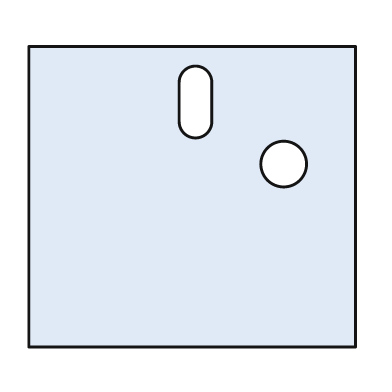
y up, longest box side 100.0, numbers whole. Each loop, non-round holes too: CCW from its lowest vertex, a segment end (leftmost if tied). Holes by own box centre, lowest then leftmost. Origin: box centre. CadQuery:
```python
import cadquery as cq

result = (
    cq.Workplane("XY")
    .moveTo(-50.0, -46.0)
    .lineTo(50.0, -46.0)
    .lineTo(50.0, 46.0)
    .lineTo(-50.0, 46.0)
    .close()
    .moveTo(28.0, 10.0)
    .circle(7.0)
    .moveTo(-4.0, 23.0)
    .threePointArc((1.0, 18.0), (6.0, 23.0))
    .lineTo(6.0, 35.0)
    .threePointArc((1.0, 40.0), (-4.0, 35.0))
    .close()
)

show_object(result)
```